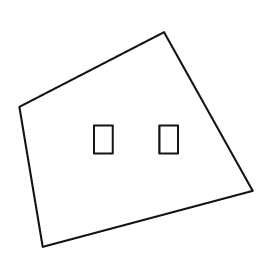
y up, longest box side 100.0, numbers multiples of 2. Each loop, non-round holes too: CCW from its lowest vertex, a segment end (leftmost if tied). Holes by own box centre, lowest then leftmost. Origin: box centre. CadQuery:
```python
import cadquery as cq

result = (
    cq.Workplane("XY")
    .moveTo(-40.0, -46.0)
    .lineTo(50.0, -22.0)
    .lineTo(12.0, 46.0)
    .lineTo(-50.0, 14.0)
    .close()
    .moveTo(-18.0, -6.0)
    .lineTo(-10.0, -6.0)
    .lineTo(-10.0, 6.0)
    .lineTo(-18.0, 6.0)
    .close()
    .moveTo(10.0, -6.0)
    .lineTo(18.0, -6.0)
    .lineTo(18.0, 6.0)
    .lineTo(10.0, 6.0)
    .close()
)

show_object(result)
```